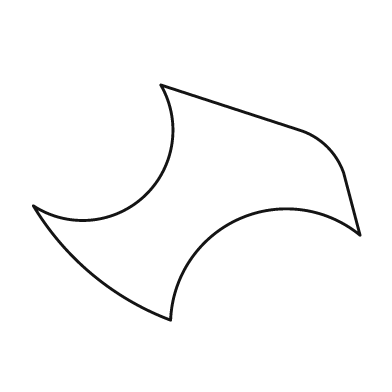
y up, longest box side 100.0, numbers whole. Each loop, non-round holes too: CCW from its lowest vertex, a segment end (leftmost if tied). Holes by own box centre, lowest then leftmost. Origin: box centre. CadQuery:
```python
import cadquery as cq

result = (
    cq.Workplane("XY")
    .moveTo(-8.0, -36.0)
    .threePointArc((13.0, -5.0), (50.0, -10.0))
    .lineTo(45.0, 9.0)
    .threePointArc((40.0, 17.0), (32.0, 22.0))
    .lineTo(-11.0, 36.0)
    .threePointArc((-16.0, 2.0), (-50.0, -1.0))
    .threePointArc((-32.0, -22.0), (-8.0, -36.0))
    .close()
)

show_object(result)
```